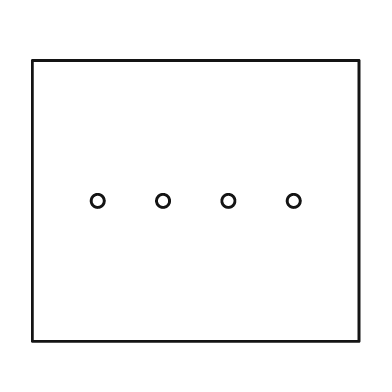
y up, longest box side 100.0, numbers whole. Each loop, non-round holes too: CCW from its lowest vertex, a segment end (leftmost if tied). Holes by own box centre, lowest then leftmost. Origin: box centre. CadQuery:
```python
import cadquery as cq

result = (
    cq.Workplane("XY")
    .moveTo(-50.0, -43.0)
    .lineTo(50.0, -43.0)
    .lineTo(50.0, 43.0)
    .lineTo(-50.0, 43.0)
    .close()
    .moveTo(-30.0, 0.0)
    .circle(2.0)
    .moveTo(-10.0, 0.0)
    .circle(2.0)
    .moveTo(10.0, 0.0)
    .circle(2.0)
    .moveTo(30.0, 0.0)
    .circle(2.0)
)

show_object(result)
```